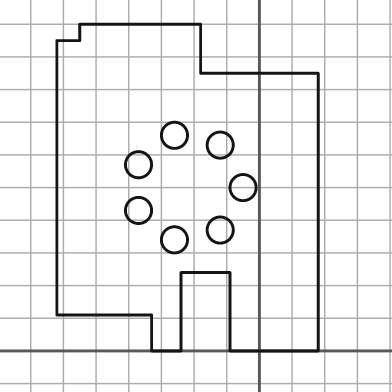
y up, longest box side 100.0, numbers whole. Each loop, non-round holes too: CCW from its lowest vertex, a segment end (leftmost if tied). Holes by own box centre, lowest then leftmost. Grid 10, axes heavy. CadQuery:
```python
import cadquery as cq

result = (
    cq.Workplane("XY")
    .moveTo(-33.0, 0.0)
    .lineTo(-24.0, 0.0)
    .lineTo(-24.0, 24.0)
    .lineTo(-9.0, 24.0)
    .lineTo(-9.0, 0.0)
    .lineTo(18.0, 0.0)
    .lineTo(18.0, 85.0)
    .lineTo(-18.0, 85.0)
    .lineTo(-18.0, 100.0)
    .lineTo(-55.0, 100.0)
    .lineTo(-55.0, 95.0)
    .lineTo(-62.0, 95.0)
    .lineTo(-62.0, 11.0)
    .lineTo(-33.0, 11.0)
    .close()
    .moveTo(-26.0, 34.0)
    .circle(4.0)
    .moveTo(-12.0, 37.0)
    .circle(4.0)
    .moveTo(-37.0, 43.0)
    .circle(4.0)
    .moveTo(-5.0, 50.0)
    .circle(4.0)
    .moveTo(-37.0, 57.0)
    .circle(4.0)
    .moveTo(-12.0, 63.0)
    .circle(4.0)
    .moveTo(-26.0, 66.0)
    .circle(4.0)
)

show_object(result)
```